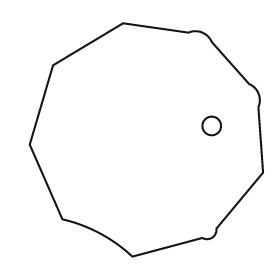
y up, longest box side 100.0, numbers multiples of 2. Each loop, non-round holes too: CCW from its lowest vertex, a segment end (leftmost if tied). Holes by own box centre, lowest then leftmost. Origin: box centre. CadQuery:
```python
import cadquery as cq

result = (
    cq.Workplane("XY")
    .moveTo(-6.0, -50.0)
    .lineTo(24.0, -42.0)
    .threePointArc((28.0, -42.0), (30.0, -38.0))
    .lineTo(50.0, -14.0)
    .lineTo(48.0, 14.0)
    .threePointArc((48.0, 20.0), (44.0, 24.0))
    .lineTo(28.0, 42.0)
    .threePointArc((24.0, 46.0), (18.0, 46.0))
    .lineTo(-10.0, 50.0)
    .lineTo(-40.0, 32.0)
    .lineTo(-50.0, -2.0)
    .lineTo(-36.0, -34.0)
    .threePointArc((-20.0, -40.0), (-6.0, -50.0))
    .close()
    .moveTo(28.0, 6.0)
    .circle(4.0)
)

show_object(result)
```